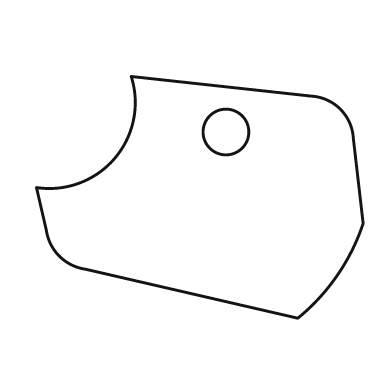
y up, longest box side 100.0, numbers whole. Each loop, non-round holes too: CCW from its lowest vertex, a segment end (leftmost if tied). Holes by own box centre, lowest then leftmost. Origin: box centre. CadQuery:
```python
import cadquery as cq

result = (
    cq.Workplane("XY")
    .moveTo(30.0, -37.0)
    .threePointArc((42.0, -24.0), (50.0, -8.0))
    .lineTo(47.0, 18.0)
    .threePointArc((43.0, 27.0), (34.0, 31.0))
    .lineTo(-21.0, 37.0)
    .threePointArc((-26.0, 12.0), (-50.0, 3.0))
    .lineTo(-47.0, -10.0)
    .threePointArc((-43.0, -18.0), (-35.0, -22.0))
    .close()
    .moveTo(8.0, 20.0)
    .circle(7.0)
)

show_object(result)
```